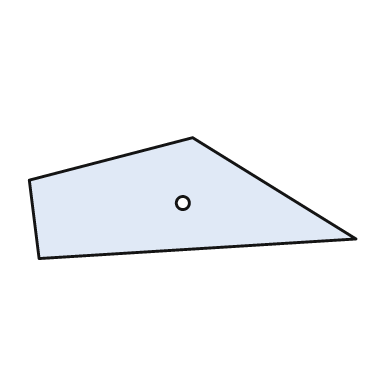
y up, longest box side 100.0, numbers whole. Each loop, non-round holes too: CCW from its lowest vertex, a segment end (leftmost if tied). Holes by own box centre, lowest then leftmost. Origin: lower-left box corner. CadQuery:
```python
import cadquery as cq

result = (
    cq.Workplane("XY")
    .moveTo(3.0, 0.0)
    .lineTo(100.0, 6.0)
    .lineTo(50.0, 37.0)
    .lineTo(0.0, 24.0)
    .close()
    .moveTo(47.0, 17.0)
    .circle(2.0)
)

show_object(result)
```